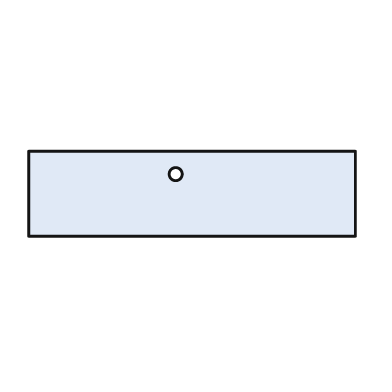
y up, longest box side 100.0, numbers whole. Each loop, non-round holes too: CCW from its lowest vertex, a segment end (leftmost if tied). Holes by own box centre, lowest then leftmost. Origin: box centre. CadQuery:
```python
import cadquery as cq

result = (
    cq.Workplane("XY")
    .moveTo(-50.0, -13.0)
    .lineTo(50.0, -13.0)
    .lineTo(50.0, 13.0)
    .lineTo(-50.0, 13.0)
    .close()
    .moveTo(-5.0, 6.0)
    .circle(2.0)
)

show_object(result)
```